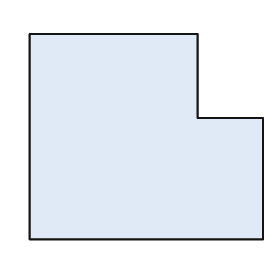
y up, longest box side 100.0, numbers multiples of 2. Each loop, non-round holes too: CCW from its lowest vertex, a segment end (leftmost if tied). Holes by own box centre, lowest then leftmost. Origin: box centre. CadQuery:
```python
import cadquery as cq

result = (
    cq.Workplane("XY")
    .moveTo(-50.0, -44.0)
    .lineTo(50.0, -44.0)
    .lineTo(50.0, 8.0)
    .lineTo(22.0, 8.0)
    .lineTo(22.0, 44.0)
    .lineTo(-50.0, 44.0)
    .close()
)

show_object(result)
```